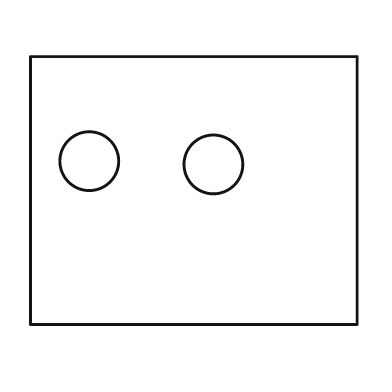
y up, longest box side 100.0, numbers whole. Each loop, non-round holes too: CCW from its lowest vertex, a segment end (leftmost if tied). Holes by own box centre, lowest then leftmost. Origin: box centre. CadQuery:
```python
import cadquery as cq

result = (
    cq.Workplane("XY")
    .moveTo(-50.0, -41.0)
    .lineTo(50.0, -41.0)
    .lineTo(50.0, 41.0)
    .lineTo(-50.0, 41.0)
    .close()
    .moveTo(6.0, 8.0)
    .circle(9.0)
    .moveTo(-32.0, 9.0)
    .circle(9.0)
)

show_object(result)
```